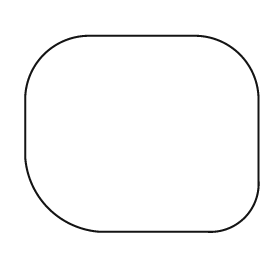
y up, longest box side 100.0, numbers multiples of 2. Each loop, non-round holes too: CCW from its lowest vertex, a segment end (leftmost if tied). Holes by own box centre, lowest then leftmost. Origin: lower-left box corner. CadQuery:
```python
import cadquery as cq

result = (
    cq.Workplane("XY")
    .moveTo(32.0, 0.0)
    .lineTo(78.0, 0.0)
    .threePointArc((94.0, 6.0), (100.0, 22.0))
    .lineTo(100.0, 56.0)
    .threePointArc((92.0, 76.0), (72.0, 84.0))
    .lineTo(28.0, 84.0)
    .threePointArc((8.0, 76.0), (0.0, 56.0))
    .lineTo(0.0, 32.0)
    .threePointArc((10.0, 10.0), (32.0, 0.0))
    .close()
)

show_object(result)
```